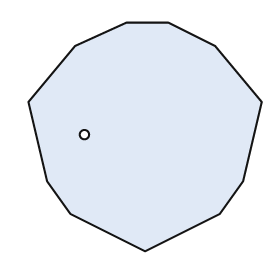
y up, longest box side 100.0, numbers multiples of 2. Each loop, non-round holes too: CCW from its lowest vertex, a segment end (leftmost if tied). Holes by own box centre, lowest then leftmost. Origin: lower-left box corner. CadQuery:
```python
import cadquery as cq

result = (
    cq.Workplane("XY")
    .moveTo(50.0, 0.0)
    .lineTo(82.0, 16.0)
    .lineTo(92.0, 30.0)
    .lineTo(100.0, 64.0)
    .lineTo(80.0, 88.0)
    .lineTo(60.0, 98.0)
    .lineTo(42.0, 98.0)
    .lineTo(20.0, 88.0)
    .lineTo(0.0, 64.0)
    .lineTo(8.0, 30.0)
    .lineTo(18.0, 16.0)
    .close()
    .moveTo(24.0, 50.0)
    .circle(2.0)
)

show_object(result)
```